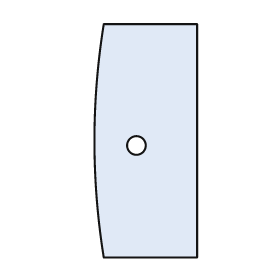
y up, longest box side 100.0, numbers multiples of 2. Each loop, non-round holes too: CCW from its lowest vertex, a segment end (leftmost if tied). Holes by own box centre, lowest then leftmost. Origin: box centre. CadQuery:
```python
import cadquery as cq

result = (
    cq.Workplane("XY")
    .moveTo(-18.0, -50.0)
    .lineTo(22.0, -50.0)
    .lineTo(22.0, 50.0)
    .lineTo(-18.0, 50.0)
    .threePointArc((-22.0, 0.0), (-18.0, -50.0))
    .close()
    .moveTo(-4.0, -2.0)
    .circle(4.0)
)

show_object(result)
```